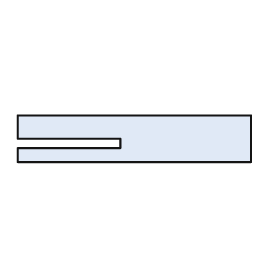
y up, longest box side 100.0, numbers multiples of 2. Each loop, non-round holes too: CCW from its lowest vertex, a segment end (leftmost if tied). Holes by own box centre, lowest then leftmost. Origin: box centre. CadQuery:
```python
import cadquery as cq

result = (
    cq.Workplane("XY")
    .moveTo(-50.0, -10.0)
    .lineTo(50.0, -10.0)
    .lineTo(50.0, 10.0)
    .lineTo(-50.0, 10.0)
    .lineTo(-50.0, 0.0)
    .lineTo(-6.0, 0.0)
    .lineTo(-6.0, -4.0)
    .lineTo(-50.0, -4.0)
    .close()
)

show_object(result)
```